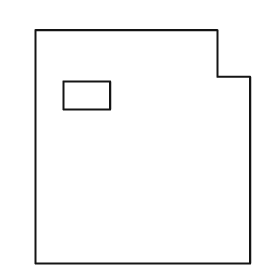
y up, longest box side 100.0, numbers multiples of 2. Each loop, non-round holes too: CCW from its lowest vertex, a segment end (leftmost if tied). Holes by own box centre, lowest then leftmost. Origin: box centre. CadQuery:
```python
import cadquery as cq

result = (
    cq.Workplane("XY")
    .moveTo(-46.0, -50.0)
    .lineTo(46.0, -50.0)
    .lineTo(46.0, 30.0)
    .lineTo(32.0, 30.0)
    .lineTo(32.0, 50.0)
    .lineTo(-46.0, 50.0)
    .close()
    .moveTo(-34.0, 16.0)
    .lineTo(-14.0, 16.0)
    .lineTo(-14.0, 28.0)
    .lineTo(-34.0, 28.0)
    .close()
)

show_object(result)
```